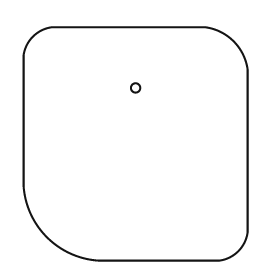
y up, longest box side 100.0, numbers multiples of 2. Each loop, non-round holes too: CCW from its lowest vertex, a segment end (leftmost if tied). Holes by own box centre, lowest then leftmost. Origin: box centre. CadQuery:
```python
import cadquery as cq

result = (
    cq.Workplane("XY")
    .moveTo(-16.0, -50.0)
    .lineTo(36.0, -50.0)
    .threePointArc((44.0, -46.0), (48.0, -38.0))
    .lineTo(48.0, 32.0)
    .threePointArc((42.0, 44.0), (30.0, 50.0))
    .lineTo(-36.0, 50.0)
    .threePointArc((-44.0, 46.0), (-48.0, 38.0))
    .lineTo(-48.0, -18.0)
    .threePointArc((-38.0, -40.0), (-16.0, -50.0))
    .close()
    .moveTo(0.0, 24.0)
    .circle(2.0)
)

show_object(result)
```